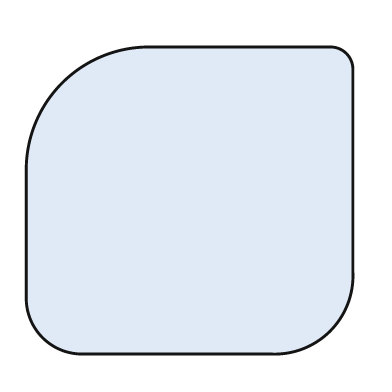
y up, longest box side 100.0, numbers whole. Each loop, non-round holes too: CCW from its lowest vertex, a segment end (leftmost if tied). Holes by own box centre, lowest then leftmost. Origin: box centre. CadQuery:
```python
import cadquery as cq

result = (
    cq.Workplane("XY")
    .moveTo(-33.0, -47.0)
    .lineTo(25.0, -47.0)
    .threePointArc((43.0, -40.0), (50.0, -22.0))
    .lineTo(50.0, 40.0)
    .threePointArc((48.0, 45.0), (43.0, 47.0))
    .lineTo(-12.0, 47.0)
    .threePointArc((-39.0, 36.0), (-50.0, 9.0))
    .lineTo(-50.0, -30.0)
    .threePointArc((-45.0, -42.0), (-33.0, -47.0))
    .close()
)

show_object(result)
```